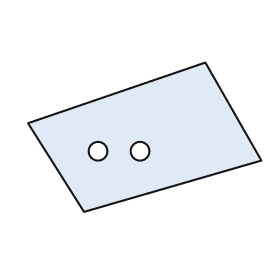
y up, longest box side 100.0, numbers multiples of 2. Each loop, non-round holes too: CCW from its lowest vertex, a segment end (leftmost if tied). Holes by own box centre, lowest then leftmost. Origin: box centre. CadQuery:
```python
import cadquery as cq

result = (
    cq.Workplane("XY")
    .moveTo(-26.0, -32.0)
    .lineTo(50.0, -10.0)
    .lineTo(26.0, 32.0)
    .lineTo(-50.0, 6.0)
    .close()
    .moveTo(-20.0, -6.0)
    .circle(4.0)
    .moveTo(-2.0, -6.0)
    .circle(4.0)
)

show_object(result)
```